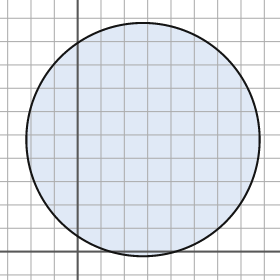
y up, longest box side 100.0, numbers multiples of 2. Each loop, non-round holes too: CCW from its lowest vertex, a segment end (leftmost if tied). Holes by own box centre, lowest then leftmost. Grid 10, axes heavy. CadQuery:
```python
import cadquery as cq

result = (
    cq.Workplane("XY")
    .moveTo(28.0, 48.0)
    .circle(50.0)
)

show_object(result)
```